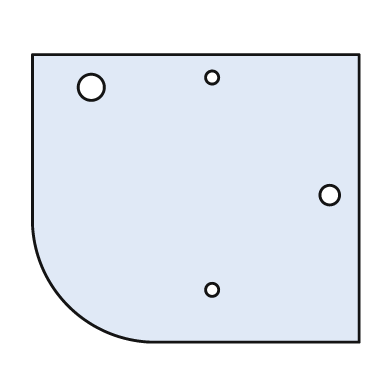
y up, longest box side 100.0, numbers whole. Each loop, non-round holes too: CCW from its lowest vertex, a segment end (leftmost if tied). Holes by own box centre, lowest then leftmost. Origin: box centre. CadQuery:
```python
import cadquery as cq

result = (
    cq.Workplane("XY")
    .moveTo(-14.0, -44.0)
    .lineTo(50.0, -44.0)
    .lineTo(50.0, 44.0)
    .lineTo(-50.0, 44.0)
    .lineTo(-50.0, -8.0)
    .threePointArc((-39.0, -33.0), (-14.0, -44.0))
    .close()
    .moveTo(5.0, -28.0)
    .circle(2.0)
    .moveTo(41.0, 1.0)
    .circle(3.0)
    .moveTo(-32.0, 34.0)
    .circle(4.0)
    .moveTo(5.0, 37.0)
    .circle(2.0)
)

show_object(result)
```